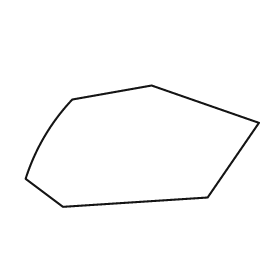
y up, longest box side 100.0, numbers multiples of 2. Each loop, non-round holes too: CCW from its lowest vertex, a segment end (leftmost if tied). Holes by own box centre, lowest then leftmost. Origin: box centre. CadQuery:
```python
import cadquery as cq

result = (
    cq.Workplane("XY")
    .moveTo(-34.0, -26.0)
    .lineTo(28.0, -22.0)
    .lineTo(50.0, 10.0)
    .lineTo(4.0, 26.0)
    .lineTo(-30.0, 20.0)
    .threePointArc((-42.0, 4.0), (-50.0, -14.0))
    .close()
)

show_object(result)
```